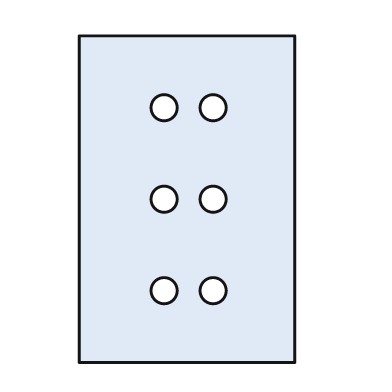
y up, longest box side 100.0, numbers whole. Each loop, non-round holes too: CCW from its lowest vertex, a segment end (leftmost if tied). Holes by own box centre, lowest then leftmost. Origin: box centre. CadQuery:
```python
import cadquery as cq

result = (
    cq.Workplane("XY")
    .moveTo(-33.0, -50.0)
    .lineTo(33.0, -50.0)
    .lineTo(33.0, 50.0)
    .lineTo(-33.0, 50.0)
    .close()
    .moveTo(-7.0, -28.0)
    .circle(4.0)
    .moveTo(8.0, -28.0)
    .circle(4.0)
    .moveTo(-7.0, 0.0)
    .circle(4.0)
    .moveTo(8.0, 0.0)
    .circle(4.0)
    .moveTo(-7.0, 28.0)
    .circle(4.0)
    .moveTo(8.0, 28.0)
    .circle(4.0)
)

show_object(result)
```